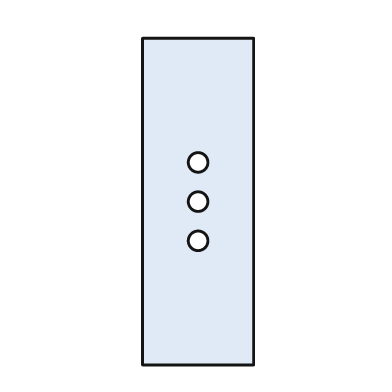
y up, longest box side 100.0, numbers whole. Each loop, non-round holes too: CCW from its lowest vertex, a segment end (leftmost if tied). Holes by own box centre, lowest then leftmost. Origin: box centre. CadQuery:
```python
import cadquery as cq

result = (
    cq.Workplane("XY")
    .moveTo(-17.0, -50.0)
    .lineTo(17.0, -50.0)
    .lineTo(17.0, 50.0)
    .lineTo(-17.0, 50.0)
    .close()
    .moveTo(0.0, -12.0)
    .circle(3.0)
    .moveTo(0.0, 0.0)
    .circle(3.0)
    .moveTo(0.0, 12.0)
    .circle(3.0)
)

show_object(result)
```